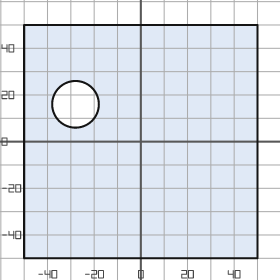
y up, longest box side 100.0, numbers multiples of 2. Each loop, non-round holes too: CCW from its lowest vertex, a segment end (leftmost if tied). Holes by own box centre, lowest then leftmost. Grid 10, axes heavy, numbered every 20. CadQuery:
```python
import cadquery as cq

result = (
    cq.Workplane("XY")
    .moveTo(-50.0, -50.0)
    .lineTo(50.0, -50.0)
    .lineTo(50.0, 50.0)
    .lineTo(-50.0, 50.0)
    .close()
    .moveTo(-28.0, 16.0)
    .circle(10.0)
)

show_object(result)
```